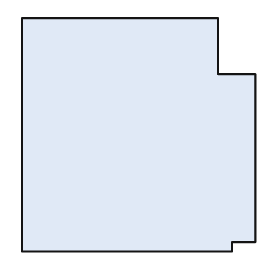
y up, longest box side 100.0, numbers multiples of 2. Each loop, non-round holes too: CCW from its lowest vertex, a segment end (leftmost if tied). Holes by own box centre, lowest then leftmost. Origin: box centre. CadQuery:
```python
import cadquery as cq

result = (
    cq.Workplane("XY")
    .moveTo(-50.0, -50.0)
    .lineTo(40.0, -50.0)
    .lineTo(40.0, -46.0)
    .lineTo(50.0, -46.0)
    .lineTo(50.0, 26.0)
    .lineTo(34.0, 26.0)
    .lineTo(34.0, 50.0)
    .lineTo(-50.0, 50.0)
    .close()
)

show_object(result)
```